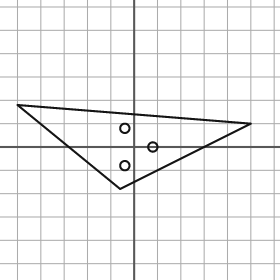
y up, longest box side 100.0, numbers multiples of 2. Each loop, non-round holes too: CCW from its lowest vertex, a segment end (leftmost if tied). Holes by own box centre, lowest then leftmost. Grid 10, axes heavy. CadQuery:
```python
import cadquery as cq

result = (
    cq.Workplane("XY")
    .moveTo(-6.0, -18.0)
    .lineTo(50.0, 10.0)
    .lineTo(-50.0, 18.0)
    .close()
    .moveTo(-4.0, -8.0)
    .circle(2.0)
    .moveTo(8.0, 0.0)
    .circle(2.0)
    .moveTo(-4.0, 8.0)
    .circle(2.0)
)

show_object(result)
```